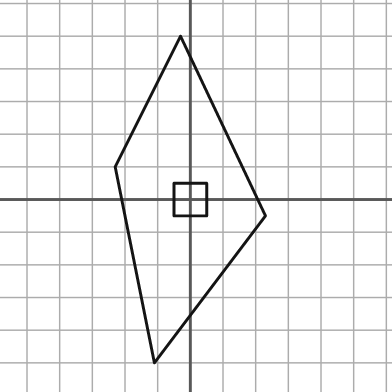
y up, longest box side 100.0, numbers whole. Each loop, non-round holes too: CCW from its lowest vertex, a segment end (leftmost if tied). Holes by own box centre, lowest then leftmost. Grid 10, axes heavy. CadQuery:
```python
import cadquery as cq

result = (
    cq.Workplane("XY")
    .moveTo(-11.0, -50.0)
    .lineTo(23.0, -5.0)
    .lineTo(-3.0, 50.0)
    .lineTo(-23.0, 10.0)
    .close()
    .moveTo(-5.0, -5.0)
    .lineTo(5.0, -5.0)
    .lineTo(5.0, 5.0)
    .lineTo(-5.0, 5.0)
    .close()
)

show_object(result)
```